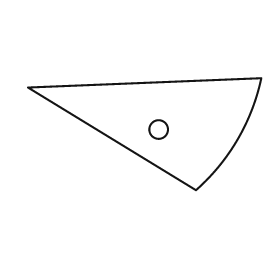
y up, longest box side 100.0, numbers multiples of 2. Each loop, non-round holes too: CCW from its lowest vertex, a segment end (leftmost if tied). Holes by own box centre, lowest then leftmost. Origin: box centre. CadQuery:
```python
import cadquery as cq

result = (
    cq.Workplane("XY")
    .moveTo(22.0, -24.0)
    .threePointArc((40.0, -2.0), (50.0, 24.0))
    .lineTo(-50.0, 20.0)
    .close()
    .moveTo(6.0, 2.0)
    .circle(4.0)
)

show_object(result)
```